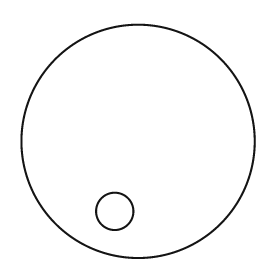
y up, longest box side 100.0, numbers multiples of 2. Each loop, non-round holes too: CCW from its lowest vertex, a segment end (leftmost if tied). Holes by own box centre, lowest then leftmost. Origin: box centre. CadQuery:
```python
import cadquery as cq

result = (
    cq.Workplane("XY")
    .moveTo(0.0, 0.0)
    .circle(50.0)
    .moveTo(-10.0, -30.0)
    .circle(8.0)
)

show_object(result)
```